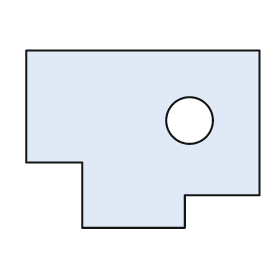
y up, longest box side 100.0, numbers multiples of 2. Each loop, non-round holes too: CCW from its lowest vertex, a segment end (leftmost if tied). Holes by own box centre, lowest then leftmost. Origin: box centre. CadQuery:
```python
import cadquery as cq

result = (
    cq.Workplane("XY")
    .moveTo(-26.0, -38.0)
    .lineTo(18.0, -38.0)
    .lineTo(18.0, -24.0)
    .lineTo(50.0, -24.0)
    .lineTo(50.0, 38.0)
    .lineTo(-50.0, 38.0)
    .lineTo(-50.0, -10.0)
    .lineTo(-26.0, -10.0)
    .close()
    .moveTo(20.0, 8.0)
    .circle(10.0)
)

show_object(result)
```